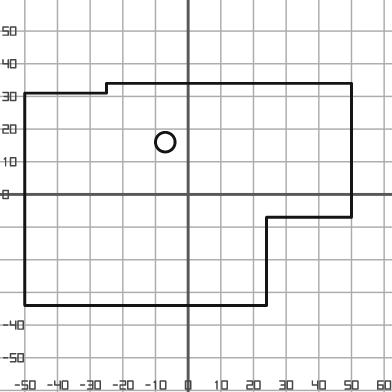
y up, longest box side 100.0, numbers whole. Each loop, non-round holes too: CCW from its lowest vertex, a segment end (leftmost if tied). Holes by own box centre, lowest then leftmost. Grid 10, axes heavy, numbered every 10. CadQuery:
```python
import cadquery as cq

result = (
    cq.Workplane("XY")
    .moveTo(-50.0, -34.0)
    .lineTo(24.0, -34.0)
    .lineTo(24.0, -7.0)
    .lineTo(50.0, -7.0)
    .lineTo(50.0, 34.0)
    .lineTo(-25.0, 34.0)
    .lineTo(-25.0, 31.0)
    .lineTo(-50.0, 31.0)
    .close()
    .moveTo(-7.0, 16.0)
    .circle(3.0)
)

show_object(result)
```